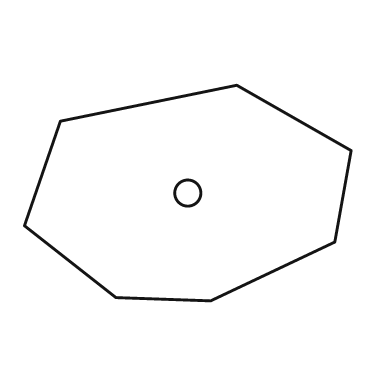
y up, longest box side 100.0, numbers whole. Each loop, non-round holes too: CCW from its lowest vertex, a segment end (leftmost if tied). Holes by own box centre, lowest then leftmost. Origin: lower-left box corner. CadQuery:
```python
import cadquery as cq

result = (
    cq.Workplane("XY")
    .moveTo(57.0, 0.0)
    .lineTo(95.0, 18.0)
    .lineTo(100.0, 46.0)
    .lineTo(65.0, 66.0)
    .lineTo(11.0, 55.0)
    .lineTo(0.0, 23.0)
    .lineTo(28.0, 1.0)
    .close()
    .moveTo(50.0, 33.0)
    .circle(4.0)
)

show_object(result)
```